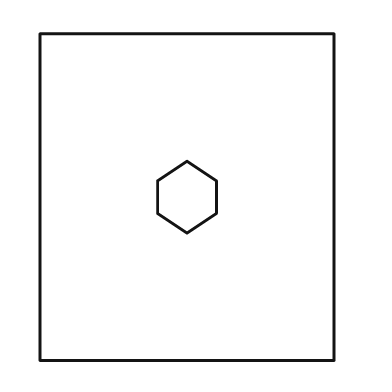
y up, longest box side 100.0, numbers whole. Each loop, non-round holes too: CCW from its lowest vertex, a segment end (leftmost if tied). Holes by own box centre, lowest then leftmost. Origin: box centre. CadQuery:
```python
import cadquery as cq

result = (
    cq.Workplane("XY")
    .moveTo(-45.0, -50.0)
    .lineTo(45.0, -50.0)
    .lineTo(45.0, 50.0)
    .lineTo(-45.0, 50.0)
    .close()
    .moveTo(0.0, -11.0)
    .lineTo(9.0, -5.0)
    .lineTo(9.0, 5.0)
    .lineTo(0.0, 11.0)
    .lineTo(-9.0, 5.0)
    .lineTo(-9.0, -5.0)
    .close()
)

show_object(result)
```